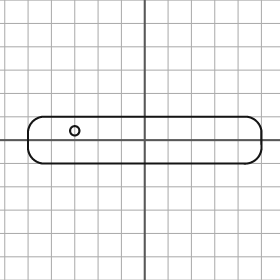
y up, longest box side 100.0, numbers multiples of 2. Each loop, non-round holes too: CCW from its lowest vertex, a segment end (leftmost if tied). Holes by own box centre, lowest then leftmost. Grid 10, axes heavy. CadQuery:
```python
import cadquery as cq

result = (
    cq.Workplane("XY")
    .moveTo(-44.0, -10.0)
    .lineTo(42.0, -10.0)
    .threePointArc((48.0, -8.0), (50.0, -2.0))
    .lineTo(50.0, 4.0)
    .threePointArc((48.0, 8.0), (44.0, 10.0))
    .lineTo(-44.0, 10.0)
    .threePointArc((-48.0, 8.0), (-50.0, 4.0))
    .lineTo(-50.0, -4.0)
    .threePointArc((-48.0, -8.0), (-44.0, -10.0))
    .close()
    .moveTo(-30.0, 4.0)
    .circle(2.0)
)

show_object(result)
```